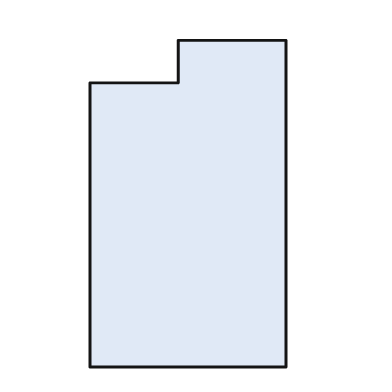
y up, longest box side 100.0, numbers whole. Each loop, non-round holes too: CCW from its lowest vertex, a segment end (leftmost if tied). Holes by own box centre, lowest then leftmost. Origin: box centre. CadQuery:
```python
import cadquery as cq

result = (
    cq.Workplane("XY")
    .moveTo(-30.0, -50.0)
    .lineTo(30.0, -50.0)
    .lineTo(30.0, 50.0)
    .lineTo(-3.0, 50.0)
    .lineTo(-3.0, 37.0)
    .lineTo(-30.0, 37.0)
    .close()
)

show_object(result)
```